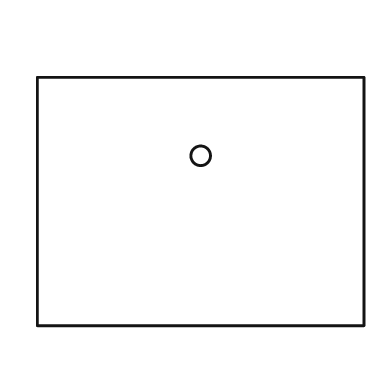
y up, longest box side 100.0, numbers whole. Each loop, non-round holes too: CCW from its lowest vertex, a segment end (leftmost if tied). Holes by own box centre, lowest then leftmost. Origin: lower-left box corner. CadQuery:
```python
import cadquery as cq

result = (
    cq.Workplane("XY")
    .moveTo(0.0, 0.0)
    .lineTo(100.0, 0.0)
    .lineTo(100.0, 76.0)
    .lineTo(0.0, 76.0)
    .close()
    .moveTo(50.0, 52.0)
    .circle(3.0)
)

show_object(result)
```